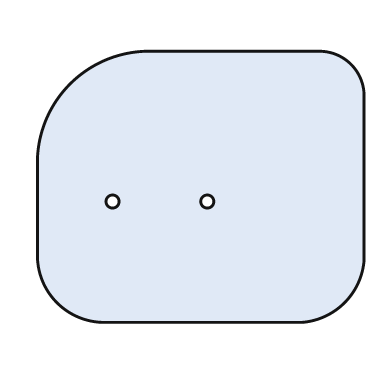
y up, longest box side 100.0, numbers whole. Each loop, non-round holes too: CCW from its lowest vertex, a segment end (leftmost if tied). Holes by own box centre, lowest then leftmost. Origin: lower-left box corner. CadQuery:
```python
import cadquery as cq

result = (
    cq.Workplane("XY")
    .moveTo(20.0, 0.0)
    .lineTo(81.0, 0.0)
    .threePointArc((94.0, 6.0), (100.0, 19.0))
    .lineTo(100.0, 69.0)
    .threePointArc((96.0, 79.0), (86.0, 83.0))
    .lineTo(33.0, 83.0)
    .threePointArc((10.0, 73.0), (0.0, 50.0))
    .lineTo(0.0, 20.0)
    .threePointArc((6.0, 6.0), (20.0, 0.0))
    .close()
    .moveTo(23.0, 37.0)
    .circle(2.0)
    .moveTo(52.0, 37.0)
    .circle(2.0)
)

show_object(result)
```